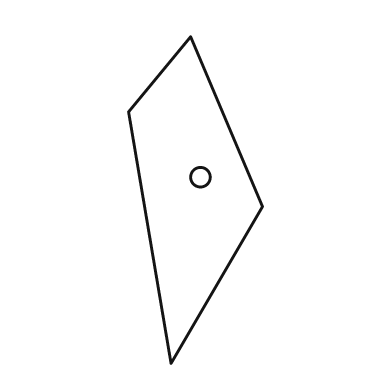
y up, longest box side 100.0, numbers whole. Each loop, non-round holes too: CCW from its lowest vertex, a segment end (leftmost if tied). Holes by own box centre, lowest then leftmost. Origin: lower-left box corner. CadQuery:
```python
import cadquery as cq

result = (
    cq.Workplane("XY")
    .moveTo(13.0, 0.0)
    .lineTo(41.0, 48.0)
    .lineTo(19.0, 100.0)
    .lineTo(0.0, 77.0)
    .close()
    .moveTo(22.0, 57.0)
    .circle(3.0)
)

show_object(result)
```